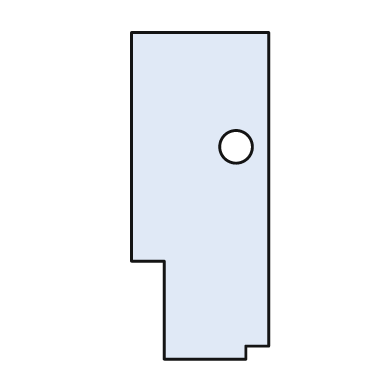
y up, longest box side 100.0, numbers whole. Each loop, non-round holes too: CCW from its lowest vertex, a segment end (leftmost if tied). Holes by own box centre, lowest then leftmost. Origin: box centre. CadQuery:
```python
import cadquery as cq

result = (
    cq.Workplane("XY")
    .moveTo(-11.0, -50.0)
    .lineTo(14.0, -50.0)
    .lineTo(14.0, -46.0)
    .lineTo(21.0, -46.0)
    .lineTo(21.0, 50.0)
    .lineTo(-21.0, 50.0)
    .lineTo(-21.0, -20.0)
    .lineTo(-11.0, -20.0)
    .close()
    .moveTo(11.0, 15.0)
    .circle(5.0)
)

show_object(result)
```